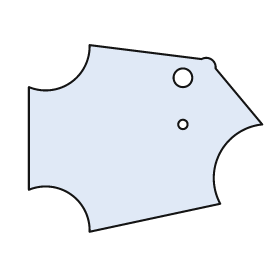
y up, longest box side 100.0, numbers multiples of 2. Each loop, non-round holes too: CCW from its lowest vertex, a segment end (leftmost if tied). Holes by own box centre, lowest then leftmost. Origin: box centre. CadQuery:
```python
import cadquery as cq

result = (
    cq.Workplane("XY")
    .moveTo(-24.0, -40.0)
    .lineTo(32.0, -28.0)
    .threePointArc((32.0, -6.0), (50.0, 6.0))
    .lineTo(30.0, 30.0)
    .threePointArc((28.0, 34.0), (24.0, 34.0))
    .lineTo(-24.0, 40.0)
    .threePointArc((-32.0, 24.0), (-50.0, 22.0))
    .lineTo(-50.0, -22.0)
    .threePointArc((-32.0, -24.0), (-24.0, -40.0))
    .close()
    .moveTo(16.0, 6.0)
    .circle(2.0)
    .moveTo(16.0, 26.0)
    .circle(4.0)
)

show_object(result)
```